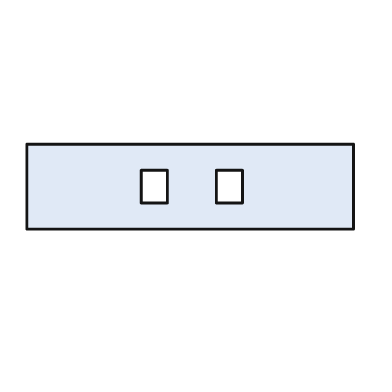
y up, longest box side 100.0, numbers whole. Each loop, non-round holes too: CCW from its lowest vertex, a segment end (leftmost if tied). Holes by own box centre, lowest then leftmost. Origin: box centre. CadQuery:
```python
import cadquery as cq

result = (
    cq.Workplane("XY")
    .moveTo(-50.0, -13.0)
    .lineTo(50.0, -13.0)
    .lineTo(50.0, 13.0)
    .lineTo(-50.0, 13.0)
    .close()
    .moveTo(-15.0, -5.0)
    .lineTo(-7.0, -5.0)
    .lineTo(-7.0, 5.0)
    .lineTo(-15.0, 5.0)
    .close()
    .moveTo(8.0, -5.0)
    .lineTo(16.0, -5.0)
    .lineTo(16.0, 5.0)
    .lineTo(8.0, 5.0)
    .close()
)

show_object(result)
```